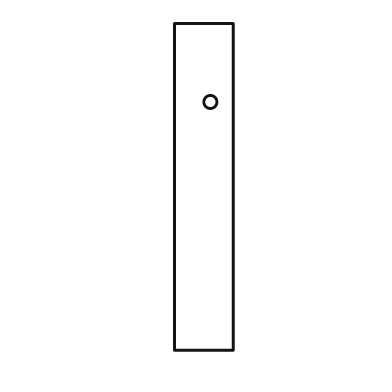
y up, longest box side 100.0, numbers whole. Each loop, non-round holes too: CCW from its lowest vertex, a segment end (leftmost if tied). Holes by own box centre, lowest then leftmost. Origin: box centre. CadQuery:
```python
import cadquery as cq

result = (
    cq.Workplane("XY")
    .moveTo(-9.0, -50.0)
    .lineTo(9.0, -50.0)
    .lineTo(9.0, 50.0)
    .lineTo(-9.0, 50.0)
    .close()
    .moveTo(2.0, 26.0)
    .circle(2.0)
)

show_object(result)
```